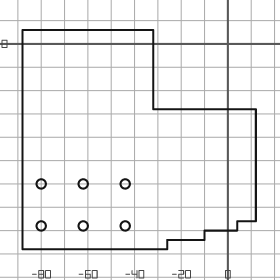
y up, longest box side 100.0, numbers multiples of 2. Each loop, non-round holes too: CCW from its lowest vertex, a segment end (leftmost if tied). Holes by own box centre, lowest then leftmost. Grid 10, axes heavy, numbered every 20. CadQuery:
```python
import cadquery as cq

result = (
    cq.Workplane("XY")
    .moveTo(-88.0, -88.0)
    .lineTo(-26.0, -88.0)
    .lineTo(-26.0, -84.0)
    .lineTo(-10.0, -84.0)
    .lineTo(-10.0, -80.0)
    .lineTo(4.0, -80.0)
    .lineTo(4.0, -76.0)
    .lineTo(12.0, -76.0)
    .lineTo(12.0, -28.0)
    .lineTo(-32.0, -28.0)
    .lineTo(-32.0, 6.0)
    .lineTo(-88.0, 6.0)
    .close()
    .moveTo(-80.0, -78.0)
    .circle(2.0)
    .moveTo(-62.0, -78.0)
    .circle(2.0)
    .moveTo(-44.0, -78.0)
    .circle(2.0)
    .moveTo(-80.0, -60.0)
    .circle(2.0)
    .moveTo(-62.0, -60.0)
    .circle(2.0)
    .moveTo(-44.0, -60.0)
    .circle(2.0)
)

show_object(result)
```